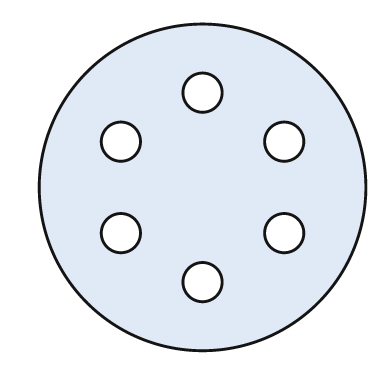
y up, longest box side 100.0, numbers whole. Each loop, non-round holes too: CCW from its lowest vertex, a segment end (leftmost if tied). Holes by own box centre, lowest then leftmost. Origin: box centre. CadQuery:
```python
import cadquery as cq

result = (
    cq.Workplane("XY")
    .moveTo(0.0, 0.0)
    .circle(50.0)
    .moveTo(0.0, -29.0)
    .circle(6.0)
    .moveTo(-25.0, -14.0)
    .circle(6.0)
    .moveTo(25.0, -14.0)
    .circle(6.0)
    .moveTo(-25.0, 14.0)
    .circle(6.0)
    .moveTo(25.0, 14.0)
    .circle(6.0)
    .moveTo(0.0, 29.0)
    .circle(6.0)
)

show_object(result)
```